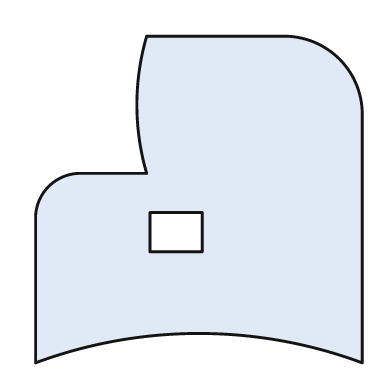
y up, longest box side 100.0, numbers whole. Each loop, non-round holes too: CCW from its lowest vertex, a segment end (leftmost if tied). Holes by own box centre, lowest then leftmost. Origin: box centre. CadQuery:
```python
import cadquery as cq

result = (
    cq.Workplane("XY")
    .moveTo(-50.0, -50.0)
    .threePointArc((0.0, -41.0), (50.0, -50.0))
    .lineTo(50.0, 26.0)
    .threePointArc((43.0, 43.0), (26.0, 50.0))
    .lineTo(-16.0, 50.0)
    .threePointArc((-19.0, 29.0), (-16.0, 8.0))
    .lineTo(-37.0, 8.0)
    .threePointArc((-46.0, 4.0), (-50.0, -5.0))
    .close()
    .moveTo(-15.0, -16.0)
    .lineTo(1.0, -16.0)
    .lineTo(1.0, -4.0)
    .lineTo(-15.0, -4.0)
    .close()
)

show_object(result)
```